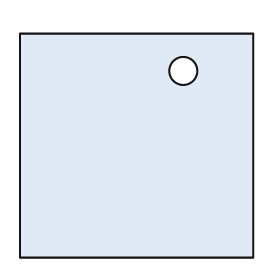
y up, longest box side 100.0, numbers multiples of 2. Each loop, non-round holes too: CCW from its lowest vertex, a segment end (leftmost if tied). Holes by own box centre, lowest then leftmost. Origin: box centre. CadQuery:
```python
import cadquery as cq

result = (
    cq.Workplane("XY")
    .moveTo(-50.0, -48.0)
    .lineTo(50.0, -48.0)
    .lineTo(50.0, 48.0)
    .lineTo(-50.0, 48.0)
    .close()
    .moveTo(20.0, 32.0)
    .circle(6.0)
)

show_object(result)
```